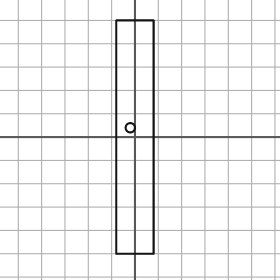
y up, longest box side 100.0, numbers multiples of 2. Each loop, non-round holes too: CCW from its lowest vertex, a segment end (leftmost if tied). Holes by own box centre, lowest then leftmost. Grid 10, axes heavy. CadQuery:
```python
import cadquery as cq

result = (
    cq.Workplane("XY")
    .moveTo(-8.0, -50.0)
    .lineTo(8.0, -50.0)
    .lineTo(8.0, 50.0)
    .lineTo(-8.0, 50.0)
    .close()
    .moveTo(-2.0, 4.0)
    .circle(2.0)
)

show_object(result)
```